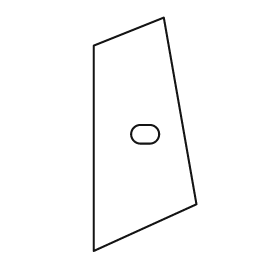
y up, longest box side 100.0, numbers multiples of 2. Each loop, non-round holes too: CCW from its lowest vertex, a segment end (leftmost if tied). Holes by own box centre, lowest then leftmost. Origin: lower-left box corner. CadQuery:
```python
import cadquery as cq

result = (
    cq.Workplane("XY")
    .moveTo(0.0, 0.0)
    .lineTo(44.0, 20.0)
    .lineTo(30.0, 100.0)
    .lineTo(0.0, 88.0)
    .close()
    .moveTo(20.0, 46.0)
    .lineTo(24.0, 46.0)
    .threePointArc((28.0, 50.0), (24.0, 54.0))
    .lineTo(20.0, 54.0)
    .threePointArc((16.0, 50.0), (20.0, 46.0))
    .close()
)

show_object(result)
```